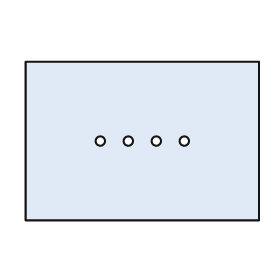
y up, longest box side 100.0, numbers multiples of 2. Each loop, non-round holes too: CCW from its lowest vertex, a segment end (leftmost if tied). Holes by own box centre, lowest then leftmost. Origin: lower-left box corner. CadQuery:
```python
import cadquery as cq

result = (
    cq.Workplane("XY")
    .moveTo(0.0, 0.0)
    .lineTo(100.0, 0.0)
    .lineTo(100.0, 68.0)
    .lineTo(0.0, 68.0)
    .close()
    .moveTo(32.0, 34.0)
    .circle(2.0)
    .moveTo(44.0, 34.0)
    .circle(2.0)
    .moveTo(56.0, 34.0)
    .circle(2.0)
    .moveTo(68.0, 34.0)
    .circle(2.0)
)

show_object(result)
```